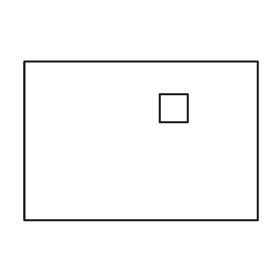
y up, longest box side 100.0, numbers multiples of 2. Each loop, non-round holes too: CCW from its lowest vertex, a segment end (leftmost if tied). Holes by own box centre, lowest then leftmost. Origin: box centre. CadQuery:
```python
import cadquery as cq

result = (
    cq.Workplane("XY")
    .moveTo(-50.0, -34.0)
    .lineTo(50.0, -34.0)
    .lineTo(50.0, 34.0)
    .lineTo(-50.0, 34.0)
    .close()
    .moveTo(8.0, 8.0)
    .lineTo(20.0, 8.0)
    .lineTo(20.0, 20.0)
    .lineTo(8.0, 20.0)
    .close()
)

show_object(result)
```